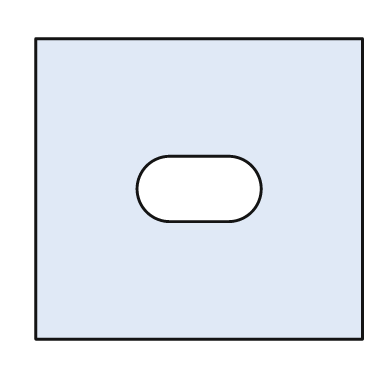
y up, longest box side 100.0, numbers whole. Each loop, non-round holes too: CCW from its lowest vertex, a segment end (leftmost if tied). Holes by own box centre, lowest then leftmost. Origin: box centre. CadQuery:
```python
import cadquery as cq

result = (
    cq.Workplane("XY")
    .moveTo(-50.0, -46.0)
    .lineTo(50.0, -46.0)
    .lineTo(50.0, 46.0)
    .lineTo(-50.0, 46.0)
    .close()
    .moveTo(-9.0, -10.0)
    .lineTo(9.0, -10.0)
    .threePointArc((19.0, 0.0), (9.0, 10.0))
    .lineTo(-9.0, 10.0)
    .threePointArc((-19.0, 0.0), (-9.0, -10.0))
    .close()
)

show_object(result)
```